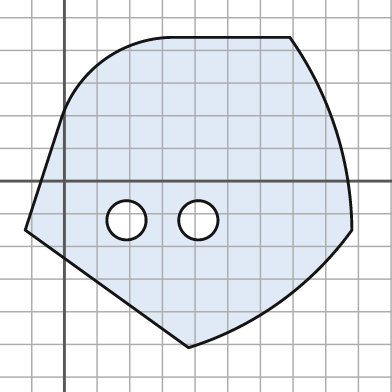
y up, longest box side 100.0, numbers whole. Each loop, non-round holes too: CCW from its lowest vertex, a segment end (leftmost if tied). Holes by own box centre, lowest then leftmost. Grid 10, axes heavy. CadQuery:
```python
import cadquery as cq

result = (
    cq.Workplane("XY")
    .moveTo(38.0, -51.0)
    .threePointArc((66.0, -37.0), (88.0, -15.0))
    .threePointArc((83.0, 16.0), (69.0, 44.0))
    .lineTo(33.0, 44.0)
    .threePointArc((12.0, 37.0), (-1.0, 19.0))
    .lineTo(-12.0, -15.0)
    .close()
    .moveTo(19.0, -12.0)
    .circle(6.0)
    .moveTo(41.0, -12.0)
    .circle(6.0)
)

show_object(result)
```